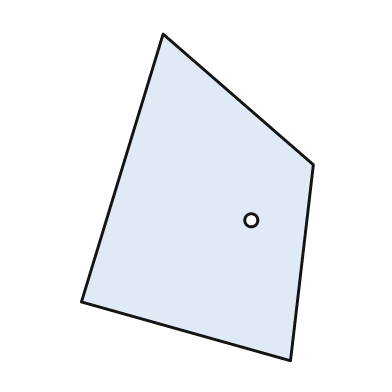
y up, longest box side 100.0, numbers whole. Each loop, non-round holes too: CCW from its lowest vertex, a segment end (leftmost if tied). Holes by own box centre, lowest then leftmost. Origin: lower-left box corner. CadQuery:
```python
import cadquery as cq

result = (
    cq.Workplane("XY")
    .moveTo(64.0, 0.0)
    .lineTo(71.0, 60.0)
    .lineTo(25.0, 100.0)
    .lineTo(0.0, 18.0)
    .close()
    .moveTo(52.0, 43.0)
    .circle(2.0)
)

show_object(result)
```